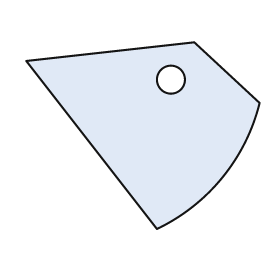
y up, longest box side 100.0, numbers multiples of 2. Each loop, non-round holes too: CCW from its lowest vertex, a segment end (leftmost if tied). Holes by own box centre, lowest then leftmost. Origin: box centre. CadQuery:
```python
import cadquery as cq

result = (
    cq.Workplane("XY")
    .moveTo(6.0, -40.0)
    .threePointArc((34.0, -18.0), (50.0, 14.0))
    .lineTo(22.0, 40.0)
    .lineTo(-50.0, 32.0)
    .close()
    .moveTo(12.0, 24.0)
    .circle(6.0)
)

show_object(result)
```